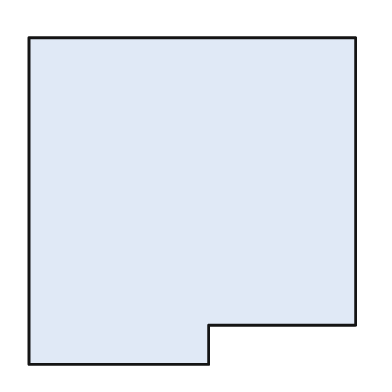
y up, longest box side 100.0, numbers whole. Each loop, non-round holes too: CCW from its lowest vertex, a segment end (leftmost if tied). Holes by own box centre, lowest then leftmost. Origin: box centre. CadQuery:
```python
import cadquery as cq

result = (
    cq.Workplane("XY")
    .moveTo(-50.0, -50.0)
    .lineTo(5.0, -50.0)
    .lineTo(5.0, -38.0)
    .lineTo(50.0, -38.0)
    .lineTo(50.0, 50.0)
    .lineTo(-50.0, 50.0)
    .close()
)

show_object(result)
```